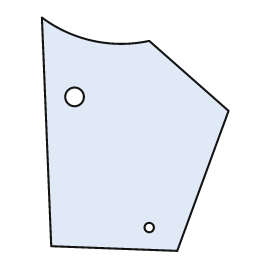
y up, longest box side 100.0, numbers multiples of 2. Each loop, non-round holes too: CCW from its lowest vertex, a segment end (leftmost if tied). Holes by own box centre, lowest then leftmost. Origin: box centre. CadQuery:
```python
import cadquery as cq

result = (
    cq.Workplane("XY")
    .moveTo(18.0, -50.0)
    .lineTo(40.0, 10.0)
    .lineTo(6.0, 40.0)
    .threePointArc((-18.0, 40.0), (-40.0, 50.0))
    .lineTo(-36.0, -48.0)
    .close()
    .moveTo(6.0, -40.0)
    .circle(2.0)
    .moveTo(-26.0, 16.0)
    .circle(4.0)
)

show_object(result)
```